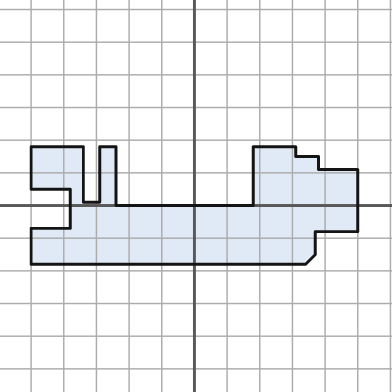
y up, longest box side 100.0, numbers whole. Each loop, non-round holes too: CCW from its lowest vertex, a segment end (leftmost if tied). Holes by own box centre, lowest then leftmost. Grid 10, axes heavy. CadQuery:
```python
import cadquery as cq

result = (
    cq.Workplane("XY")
    .moveTo(-50.0, -18.0)
    .lineTo(34.0, -18.0)
    .lineTo(37.0, -15.0)
    .lineTo(37.0, -8.0)
    .lineTo(50.0, -8.0)
    .lineTo(50.0, 11.0)
    .lineTo(38.0, 11.0)
    .lineTo(38.0, 15.0)
    .lineTo(31.0, 15.0)
    .lineTo(31.0, 18.0)
    .lineTo(18.0, 18.0)
    .lineTo(18.0, 0.0)
    .lineTo(-24.0, 0.0)
    .lineTo(-24.0, 18.0)
    .lineTo(-29.0, 18.0)
    .lineTo(-29.0, 1.0)
    .lineTo(-34.0, 1.0)
    .lineTo(-34.0, 18.0)
    .lineTo(-50.0, 18.0)
    .lineTo(-50.0, 5.0)
    .lineTo(-38.0, 5.0)
    .lineTo(-38.0, -7.0)
    .lineTo(-50.0, -7.0)
    .close()
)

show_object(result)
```